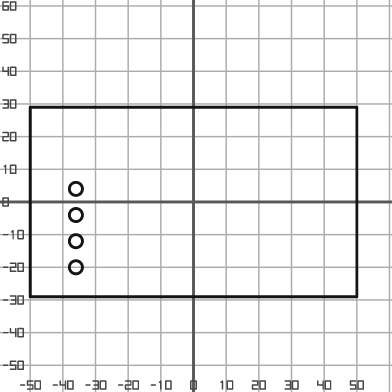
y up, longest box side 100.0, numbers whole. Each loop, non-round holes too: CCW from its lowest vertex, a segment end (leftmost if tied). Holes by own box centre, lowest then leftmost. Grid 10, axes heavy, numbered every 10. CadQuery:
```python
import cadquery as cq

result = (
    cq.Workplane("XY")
    .moveTo(-50.0, -29.0)
    .lineTo(50.0, -29.0)
    .lineTo(50.0, 29.0)
    .lineTo(-50.0, 29.0)
    .close()
    .moveTo(-36.0, -20.0)
    .circle(2.0)
    .moveTo(-36.0, -12.0)
    .circle(2.0)
    .moveTo(-36.0, -4.0)
    .circle(2.0)
    .moveTo(-36.0, 4.0)
    .circle(2.0)
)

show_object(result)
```